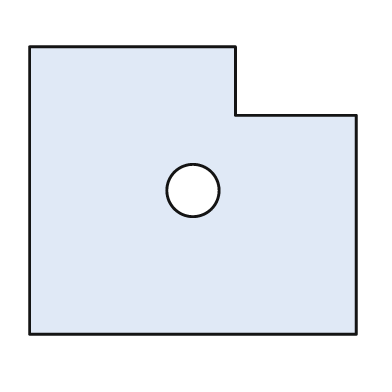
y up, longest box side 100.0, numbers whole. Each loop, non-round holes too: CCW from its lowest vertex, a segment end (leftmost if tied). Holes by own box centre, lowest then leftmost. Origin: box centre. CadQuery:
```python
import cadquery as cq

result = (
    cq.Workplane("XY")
    .moveTo(-50.0, -44.0)
    .lineTo(50.0, -44.0)
    .lineTo(50.0, 23.0)
    .lineTo(13.0, 23.0)
    .lineTo(13.0, 44.0)
    .lineTo(-50.0, 44.0)
    .close()
    .moveTo(0.0, 0.0)
    .circle(8.0)
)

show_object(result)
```